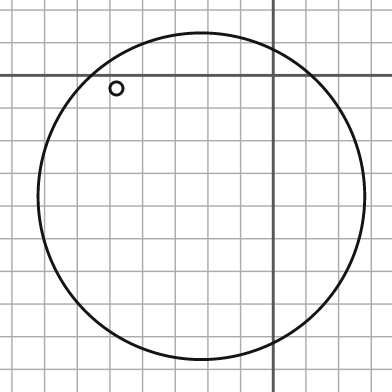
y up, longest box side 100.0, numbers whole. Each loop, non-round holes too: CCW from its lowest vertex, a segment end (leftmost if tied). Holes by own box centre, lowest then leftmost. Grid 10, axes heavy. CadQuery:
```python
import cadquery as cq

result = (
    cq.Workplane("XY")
    .moveTo(-22.0, -37.0)
    .circle(50.0)
    .moveTo(-48.0, -4.0)
    .circle(2.0)
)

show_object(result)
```